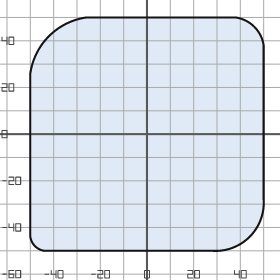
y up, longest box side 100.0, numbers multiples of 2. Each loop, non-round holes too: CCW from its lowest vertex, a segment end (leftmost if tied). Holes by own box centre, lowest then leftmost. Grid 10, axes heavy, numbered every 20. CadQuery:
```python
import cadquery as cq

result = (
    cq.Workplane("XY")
    .moveTo(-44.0, -50.0)
    .lineTo(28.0, -50.0)
    .threePointArc((44.0, -44.0), (50.0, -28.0))
    .lineTo(50.0, 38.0)
    .threePointArc((46.0, 46.0), (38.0, 50.0))
    .lineTo(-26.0, 50.0)
    .threePointArc((-42.0, 42.0), (-50.0, 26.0))
    .lineTo(-50.0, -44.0)
    .threePointArc((-48.0, -48.0), (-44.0, -50.0))
    .close()
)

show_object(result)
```